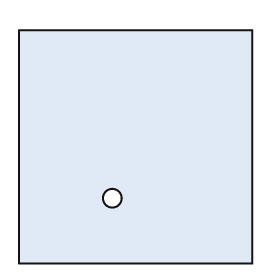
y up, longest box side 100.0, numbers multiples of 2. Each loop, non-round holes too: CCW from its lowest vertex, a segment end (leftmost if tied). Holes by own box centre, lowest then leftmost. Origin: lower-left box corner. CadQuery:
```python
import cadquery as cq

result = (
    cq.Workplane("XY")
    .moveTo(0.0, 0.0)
    .lineTo(100.0, 0.0)
    .lineTo(100.0, 100.0)
    .lineTo(0.0, 100.0)
    .close()
    .moveTo(40.0, 28.0)
    .circle(4.0)
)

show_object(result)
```